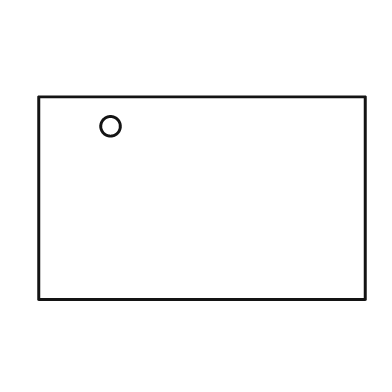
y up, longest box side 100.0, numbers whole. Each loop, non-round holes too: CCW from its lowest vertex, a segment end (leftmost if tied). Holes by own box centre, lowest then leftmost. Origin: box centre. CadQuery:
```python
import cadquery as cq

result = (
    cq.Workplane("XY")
    .moveTo(-50.0, -31.0)
    .lineTo(50.0, -31.0)
    .lineTo(50.0, 31.0)
    .lineTo(-50.0, 31.0)
    .close()
    .moveTo(-28.0, 22.0)
    .circle(3.0)
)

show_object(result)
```